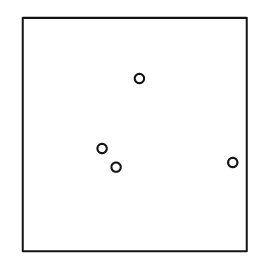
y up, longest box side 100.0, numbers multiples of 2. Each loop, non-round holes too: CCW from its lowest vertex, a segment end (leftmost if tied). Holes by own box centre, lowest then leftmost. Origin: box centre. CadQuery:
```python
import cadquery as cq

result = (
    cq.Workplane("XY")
    .moveTo(-48.0, -50.0)
    .lineTo(48.0, -50.0)
    .lineTo(48.0, 50.0)
    .lineTo(-48.0, 50.0)
    .close()
    .moveTo(-8.0, -14.0)
    .circle(2.0)
    .moveTo(42.0, -12.0)
    .circle(2.0)
    .moveTo(-14.0, -6.0)
    .circle(2.0)
    .moveTo(2.0, 24.0)
    .circle(2.0)
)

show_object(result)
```